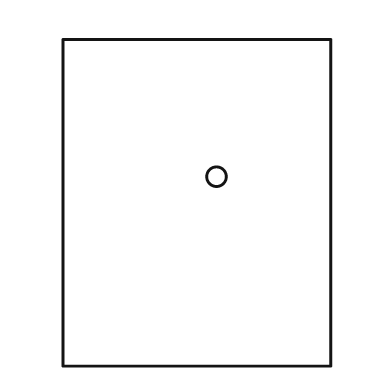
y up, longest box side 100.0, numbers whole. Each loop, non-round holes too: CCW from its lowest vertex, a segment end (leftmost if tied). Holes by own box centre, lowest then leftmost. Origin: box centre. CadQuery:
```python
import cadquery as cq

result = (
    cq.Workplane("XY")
    .moveTo(-41.0, -50.0)
    .lineTo(41.0, -50.0)
    .lineTo(41.0, 50.0)
    .lineTo(-41.0, 50.0)
    .close()
    .moveTo(6.0, 8.0)
    .circle(3.0)
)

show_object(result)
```